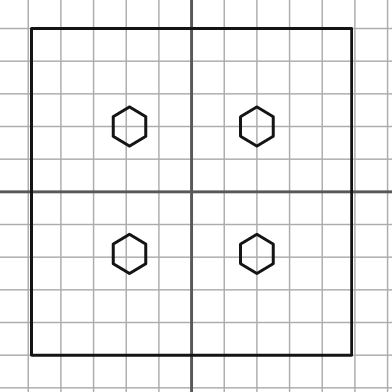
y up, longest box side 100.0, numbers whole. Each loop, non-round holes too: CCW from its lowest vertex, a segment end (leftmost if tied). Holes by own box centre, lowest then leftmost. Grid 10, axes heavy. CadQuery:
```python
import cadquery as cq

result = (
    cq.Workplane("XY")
    .moveTo(-49.0, -50.0)
    .lineTo(49.0, -50.0)
    .lineTo(49.0, 50.0)
    .lineTo(-49.0, 50.0)
    .close()
    .moveTo(-19.0, -25.0)
    .lineTo(-14.0, -22.0)
    .lineTo(-14.0, -16.0)
    .lineTo(-19.0, -13.0)
    .lineTo(-24.0, -16.0)
    .lineTo(-24.0, -22.0)
    .close()
    .moveTo(20.0, -25.0)
    .lineTo(25.0, -22.0)
    .lineTo(25.0, -16.0)
    .lineTo(20.0, -13.0)
    .lineTo(15.0, -16.0)
    .lineTo(15.0, -22.0)
    .close()
    .moveTo(-19.0, 14.0)
    .lineTo(-14.0, 17.0)
    .lineTo(-14.0, 23.0)
    .lineTo(-19.0, 26.0)
    .lineTo(-24.0, 23.0)
    .lineTo(-24.0, 17.0)
    .close()
    .moveTo(20.0, 14.0)
    .lineTo(25.0, 17.0)
    .lineTo(25.0, 23.0)
    .lineTo(20.0, 26.0)
    .lineTo(15.0, 23.0)
    .lineTo(15.0, 17.0)
    .close()
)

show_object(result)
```